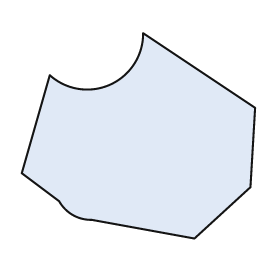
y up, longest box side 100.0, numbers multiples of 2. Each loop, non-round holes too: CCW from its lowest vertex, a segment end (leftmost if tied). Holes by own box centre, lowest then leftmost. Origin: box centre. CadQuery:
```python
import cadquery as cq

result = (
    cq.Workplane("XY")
    .moveTo(24.0, -44.0)
    .lineTo(48.0, -22.0)
    .lineTo(50.0, 12.0)
    .lineTo(2.0, 44.0)
    .threePointArc((-12.0, 22.0), (-38.0, 26.0))
    .lineTo(-50.0, -16.0)
    .lineTo(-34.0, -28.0)
    .threePointArc((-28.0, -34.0), (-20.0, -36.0))
    .close()
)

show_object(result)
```